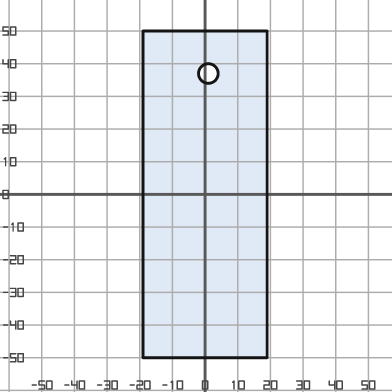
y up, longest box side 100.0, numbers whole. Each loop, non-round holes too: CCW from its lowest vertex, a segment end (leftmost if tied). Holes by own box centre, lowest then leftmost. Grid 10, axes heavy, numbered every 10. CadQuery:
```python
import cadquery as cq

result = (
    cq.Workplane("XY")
    .moveTo(-19.0, -50.0)
    .lineTo(19.0, -50.0)
    .lineTo(19.0, 50.0)
    .lineTo(-19.0, 50.0)
    .close()
    .moveTo(1.0, 37.0)
    .circle(3.0)
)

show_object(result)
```